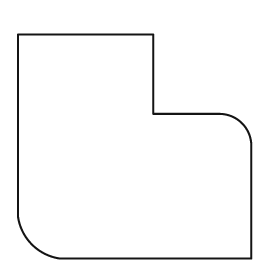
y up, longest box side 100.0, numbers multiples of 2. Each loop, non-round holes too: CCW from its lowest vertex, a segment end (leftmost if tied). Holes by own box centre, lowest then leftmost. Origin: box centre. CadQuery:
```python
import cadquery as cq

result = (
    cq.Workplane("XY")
    .moveTo(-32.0, -48.0)
    .lineTo(50.0, -48.0)
    .lineTo(50.0, 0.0)
    .threePointArc((46.0, 10.0), (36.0, 14.0))
    .lineTo(8.0, 14.0)
    .lineTo(8.0, 48.0)
    .lineTo(-50.0, 48.0)
    .lineTo(-50.0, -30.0)
    .threePointArc((-44.0, -42.0), (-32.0, -48.0))
    .close()
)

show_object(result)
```